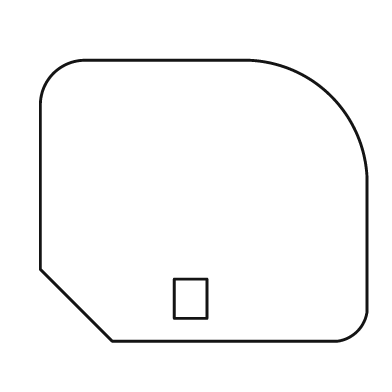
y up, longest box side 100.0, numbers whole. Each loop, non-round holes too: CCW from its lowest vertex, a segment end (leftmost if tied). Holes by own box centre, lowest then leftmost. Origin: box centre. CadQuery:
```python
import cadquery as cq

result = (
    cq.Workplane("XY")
    .moveTo(-28.0, -43.0)
    .lineTo(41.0, -43.0)
    .threePointArc((47.0, -40.0), (50.0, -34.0))
    .lineTo(50.0, 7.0)
    .threePointArc((39.0, 32.0), (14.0, 43.0))
    .lineTo(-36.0, 43.0)
    .threePointArc((-46.0, 39.0), (-50.0, 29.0))
    .lineTo(-50.0, -21.0)
    .close()
    .moveTo(-9.0, -36.0)
    .lineTo(1.0, -36.0)
    .lineTo(1.0, -24.0)
    .lineTo(-9.0, -24.0)
    .close()
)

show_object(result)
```